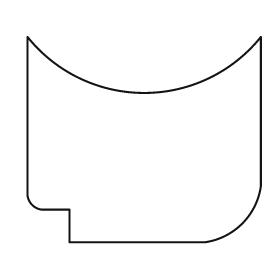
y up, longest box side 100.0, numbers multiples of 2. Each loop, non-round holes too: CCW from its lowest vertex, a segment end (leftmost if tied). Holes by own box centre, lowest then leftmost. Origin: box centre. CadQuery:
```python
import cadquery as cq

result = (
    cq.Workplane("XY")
    .moveTo(-32.0, -44.0)
    .lineTo(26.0, -44.0)
    .threePointArc((42.0, -36.0), (50.0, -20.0))
    .lineTo(50.0, 44.0)
    .threePointArc((0.0, 20.0), (-50.0, 44.0))
    .lineTo(-50.0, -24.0)
    .threePointArc((-48.0, -28.0), (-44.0, -30.0))
    .lineTo(-32.0, -30.0)
    .close()
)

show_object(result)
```